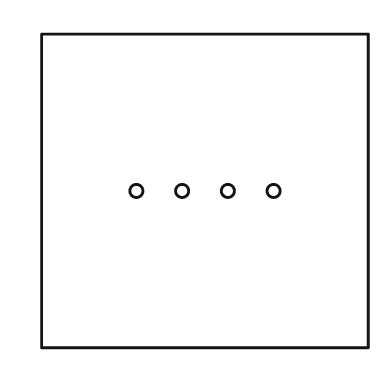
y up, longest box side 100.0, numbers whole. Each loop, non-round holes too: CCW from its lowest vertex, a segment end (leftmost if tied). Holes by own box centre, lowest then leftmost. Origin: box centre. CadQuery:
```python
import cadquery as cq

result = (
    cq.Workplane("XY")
    .moveTo(-50.0, -48.0)
    .lineTo(50.0, -48.0)
    .lineTo(50.0, 48.0)
    .lineTo(-50.0, 48.0)
    .close()
    .moveTo(-21.0, 0.0)
    .circle(2.0)
    .moveTo(-7.0, 0.0)
    .circle(2.0)
    .moveTo(7.0, 0.0)
    .circle(2.0)
    .moveTo(21.0, 0.0)
    .circle(2.0)
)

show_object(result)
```